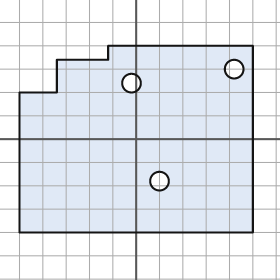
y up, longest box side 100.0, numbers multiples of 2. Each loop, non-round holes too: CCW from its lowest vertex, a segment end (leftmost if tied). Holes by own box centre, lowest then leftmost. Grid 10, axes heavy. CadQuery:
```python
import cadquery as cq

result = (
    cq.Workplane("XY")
    .moveTo(-50.0, -40.0)
    .lineTo(50.0, -40.0)
    .lineTo(50.0, 40.0)
    .lineTo(-12.0, 40.0)
    .lineTo(-12.0, 34.0)
    .lineTo(-34.0, 34.0)
    .lineTo(-34.0, 20.0)
    .lineTo(-50.0, 20.0)
    .close()
    .moveTo(10.0, -18.0)
    .circle(4.0)
    .moveTo(-2.0, 24.0)
    .circle(4.0)
    .moveTo(42.0, 30.0)
    .circle(4.0)
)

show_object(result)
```